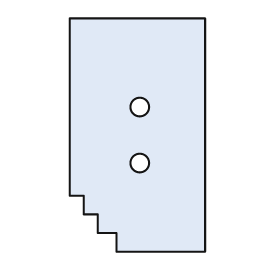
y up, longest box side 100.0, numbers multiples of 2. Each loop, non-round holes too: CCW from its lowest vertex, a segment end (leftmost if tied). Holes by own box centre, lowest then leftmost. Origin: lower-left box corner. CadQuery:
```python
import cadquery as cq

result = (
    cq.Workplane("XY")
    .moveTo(20.0, 0.0)
    .lineTo(58.0, 0.0)
    .lineTo(58.0, 100.0)
    .lineTo(0.0, 100.0)
    .lineTo(0.0, 24.0)
    .lineTo(6.0, 24.0)
    .lineTo(6.0, 16.0)
    .lineTo(12.0, 16.0)
    .lineTo(12.0, 8.0)
    .lineTo(20.0, 8.0)
    .close()
    .moveTo(30.0, 38.0)
    .circle(4.0)
    .moveTo(30.0, 62.0)
    .circle(4.0)
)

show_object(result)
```